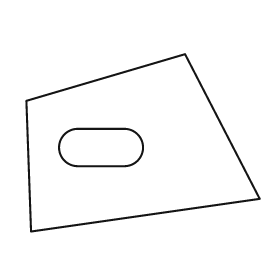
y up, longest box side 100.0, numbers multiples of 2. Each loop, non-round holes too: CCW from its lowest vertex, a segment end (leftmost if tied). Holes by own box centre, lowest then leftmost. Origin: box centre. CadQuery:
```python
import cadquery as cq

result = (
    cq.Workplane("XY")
    .moveTo(-48.0, -38.0)
    .lineTo(50.0, -24.0)
    .lineTo(18.0, 38.0)
    .lineTo(-50.0, 18.0)
    .close()
    .moveTo(-28.0, -10.0)
    .lineTo(-8.0, -10.0)
    .threePointArc((0.0, -2.0), (-8.0, 6.0))
    .lineTo(-28.0, 6.0)
    .threePointArc((-36.0, -2.0), (-28.0, -10.0))
    .close()
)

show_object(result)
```